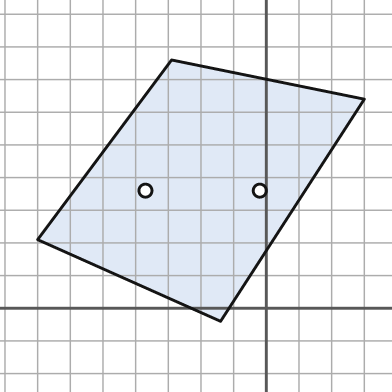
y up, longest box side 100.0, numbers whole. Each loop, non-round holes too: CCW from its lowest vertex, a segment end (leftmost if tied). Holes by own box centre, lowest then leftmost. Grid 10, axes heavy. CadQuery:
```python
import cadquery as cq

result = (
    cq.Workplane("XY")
    .moveTo(-14.0, -4.0)
    .lineTo(30.0, 64.0)
    .lineTo(-29.0, 76.0)
    .lineTo(-70.0, 21.0)
    .close()
    .moveTo(-37.0, 36.0)
    .circle(2.0)
    .moveTo(-2.0, 36.0)
    .circle(2.0)
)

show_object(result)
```